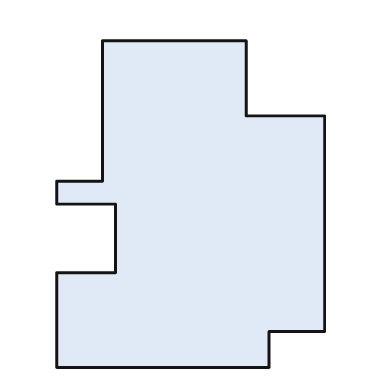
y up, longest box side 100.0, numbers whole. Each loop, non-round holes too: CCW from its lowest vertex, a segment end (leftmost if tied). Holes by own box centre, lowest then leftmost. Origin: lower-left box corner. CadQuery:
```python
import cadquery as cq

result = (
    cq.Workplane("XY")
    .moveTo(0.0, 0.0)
    .lineTo(65.0, 0.0)
    .lineTo(65.0, 11.0)
    .lineTo(82.0, 11.0)
    .lineTo(82.0, 77.0)
    .lineTo(58.0, 77.0)
    .lineTo(58.0, 100.0)
    .lineTo(14.0, 100.0)
    .lineTo(14.0, 57.0)
    .lineTo(0.0, 57.0)
    .lineTo(0.0, 50.0)
    .lineTo(18.0, 50.0)
    .lineTo(18.0, 29.0)
    .lineTo(0.0, 29.0)
    .close()
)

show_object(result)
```